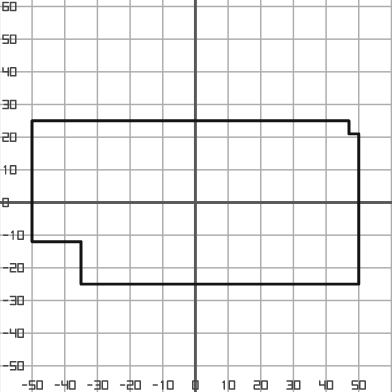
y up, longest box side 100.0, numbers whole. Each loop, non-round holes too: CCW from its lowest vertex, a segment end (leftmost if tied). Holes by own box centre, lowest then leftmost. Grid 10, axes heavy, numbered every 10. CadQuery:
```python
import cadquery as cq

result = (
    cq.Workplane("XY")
    .moveTo(-35.0, -25.0)
    .lineTo(50.0, -25.0)
    .lineTo(50.0, 21.0)
    .lineTo(47.0, 21.0)
    .lineTo(47.0, 25.0)
    .lineTo(-50.0, 25.0)
    .lineTo(-50.0, -12.0)
    .lineTo(-35.0, -12.0)
    .close()
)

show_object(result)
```